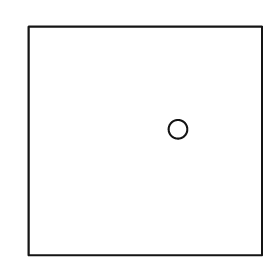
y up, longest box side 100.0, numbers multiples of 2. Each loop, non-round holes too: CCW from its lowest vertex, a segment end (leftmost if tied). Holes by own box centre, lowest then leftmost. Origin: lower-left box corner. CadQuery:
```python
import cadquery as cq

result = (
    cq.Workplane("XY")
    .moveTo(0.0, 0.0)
    .lineTo(100.0, 0.0)
    .lineTo(100.0, 98.0)
    .lineTo(0.0, 98.0)
    .close()
    .moveTo(64.0, 54.0)
    .circle(4.0)
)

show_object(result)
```